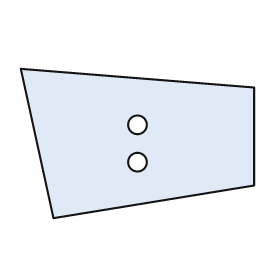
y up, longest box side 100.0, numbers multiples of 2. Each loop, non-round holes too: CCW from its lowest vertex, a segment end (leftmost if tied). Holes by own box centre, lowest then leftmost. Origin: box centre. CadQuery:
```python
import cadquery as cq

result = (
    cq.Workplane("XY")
    .moveTo(-36.0, -32.0)
    .lineTo(50.0, -18.0)
    .lineTo(50.0, 24.0)
    .lineTo(-50.0, 32.0)
    .close()
    .moveTo(0.0, -8.0)
    .circle(4.0)
    .moveTo(0.0, 8.0)
    .circle(4.0)
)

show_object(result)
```